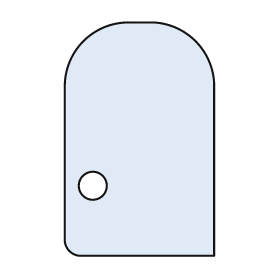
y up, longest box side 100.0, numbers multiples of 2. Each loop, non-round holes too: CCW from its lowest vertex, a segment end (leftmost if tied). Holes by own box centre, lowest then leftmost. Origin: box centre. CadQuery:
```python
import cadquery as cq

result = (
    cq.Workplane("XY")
    .moveTo(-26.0, -50.0)
    .lineTo(32.0, -50.0)
    .lineTo(32.0, 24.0)
    .threePointArc((24.0, 42.0), (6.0, 50.0))
    .lineTo(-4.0, 50.0)
    .threePointArc((-24.0, 42.0), (-32.0, 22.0))
    .lineTo(-32.0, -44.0)
    .threePointArc((-30.0, -48.0), (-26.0, -50.0))
    .close()
    .moveTo(-20.0, -20.0)
    .circle(6.0)
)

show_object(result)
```